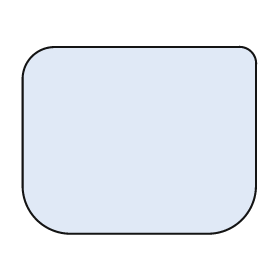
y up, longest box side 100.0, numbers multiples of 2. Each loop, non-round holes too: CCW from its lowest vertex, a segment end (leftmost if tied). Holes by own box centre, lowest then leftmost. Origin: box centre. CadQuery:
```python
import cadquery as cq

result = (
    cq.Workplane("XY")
    .moveTo(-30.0, -40.0)
    .lineTo(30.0, -40.0)
    .threePointArc((44.0, -34.0), (50.0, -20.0))
    .lineTo(50.0, 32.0)
    .threePointArc((48.0, 38.0), (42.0, 40.0))
    .lineTo(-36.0, 40.0)
    .threePointArc((-46.0, 36.0), (-50.0, 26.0))
    .lineTo(-50.0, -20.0)
    .threePointArc((-44.0, -34.0), (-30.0, -40.0))
    .close()
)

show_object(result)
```